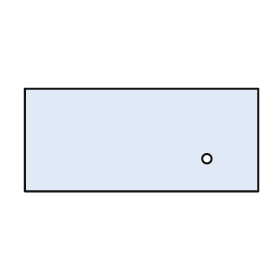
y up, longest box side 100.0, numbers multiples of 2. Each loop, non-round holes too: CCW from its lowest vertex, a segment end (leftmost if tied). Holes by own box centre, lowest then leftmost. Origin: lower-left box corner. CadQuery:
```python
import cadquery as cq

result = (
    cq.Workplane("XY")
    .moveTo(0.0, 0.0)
    .lineTo(100.0, 0.0)
    .lineTo(100.0, 44.0)
    .lineTo(0.0, 44.0)
    .close()
    .moveTo(78.0, 14.0)
    .circle(2.0)
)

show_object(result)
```